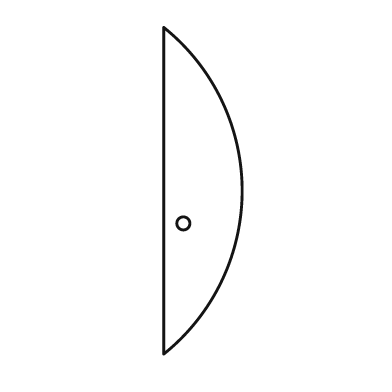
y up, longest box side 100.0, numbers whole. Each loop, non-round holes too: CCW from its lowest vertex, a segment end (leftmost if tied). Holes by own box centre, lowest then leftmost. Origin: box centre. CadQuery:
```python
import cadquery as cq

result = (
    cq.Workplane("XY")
    .moveTo(-12.0, -50.0)
    .threePointArc((12.0, 0.0), (-12.0, 50.0))
    .close()
    .moveTo(-6.0, -10.0)
    .circle(2.0)
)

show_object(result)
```